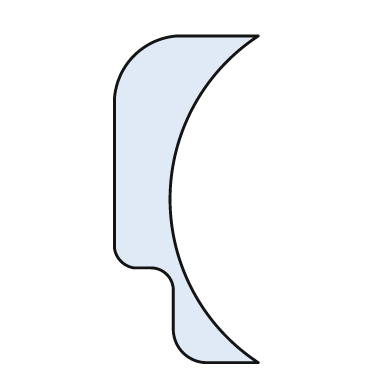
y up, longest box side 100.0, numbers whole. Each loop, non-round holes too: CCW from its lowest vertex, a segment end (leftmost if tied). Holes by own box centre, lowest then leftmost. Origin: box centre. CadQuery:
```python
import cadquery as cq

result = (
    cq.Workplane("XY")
    .moveTo(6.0, -50.0)
    .lineTo(22.0, -50.0)
    .threePointArc((-5.0, 0.0), (22.0, 50.0))
    .lineTo(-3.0, 50.0)
    .threePointArc((-16.0, 44.0), (-22.0, 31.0))
    .lineTo(-22.0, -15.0)
    .threePointArc((-20.0, -19.0), (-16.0, -21.0))
    .lineTo(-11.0, -21.0)
    .threePointArc((-6.0, -23.0), (-4.0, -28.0))
    .lineTo(-4.0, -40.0)
    .threePointArc((-1.0, -47.0), (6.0, -50.0))
    .close()
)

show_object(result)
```